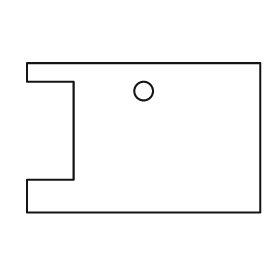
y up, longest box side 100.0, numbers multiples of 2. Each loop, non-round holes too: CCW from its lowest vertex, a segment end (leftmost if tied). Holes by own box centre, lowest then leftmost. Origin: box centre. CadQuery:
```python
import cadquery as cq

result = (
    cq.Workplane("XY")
    .moveTo(-50.0, -32.0)
    .lineTo(50.0, -32.0)
    .lineTo(50.0, 32.0)
    .lineTo(-50.0, 32.0)
    .lineTo(-50.0, 24.0)
    .lineTo(-30.0, 24.0)
    .lineTo(-30.0, -18.0)
    .lineTo(-50.0, -18.0)
    .close()
    .moveTo(0.0, 20.0)
    .circle(4.0)
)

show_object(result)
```